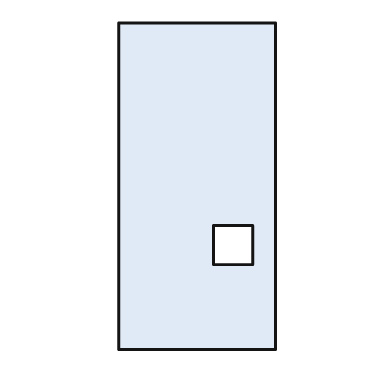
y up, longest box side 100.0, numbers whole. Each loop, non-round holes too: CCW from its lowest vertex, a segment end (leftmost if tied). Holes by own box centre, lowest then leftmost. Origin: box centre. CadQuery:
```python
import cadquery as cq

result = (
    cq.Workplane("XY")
    .moveTo(-24.0, -50.0)
    .lineTo(24.0, -50.0)
    .lineTo(24.0, 50.0)
    .lineTo(-24.0, 50.0)
    .close()
    .moveTo(5.0, -24.0)
    .lineTo(17.0, -24.0)
    .lineTo(17.0, -12.0)
    .lineTo(5.0, -12.0)
    .close()
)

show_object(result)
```